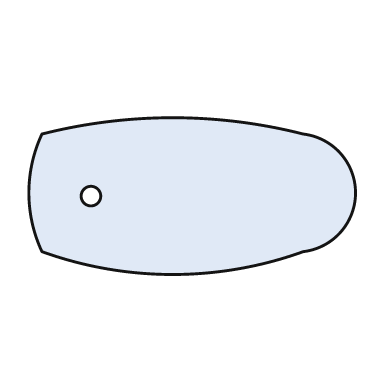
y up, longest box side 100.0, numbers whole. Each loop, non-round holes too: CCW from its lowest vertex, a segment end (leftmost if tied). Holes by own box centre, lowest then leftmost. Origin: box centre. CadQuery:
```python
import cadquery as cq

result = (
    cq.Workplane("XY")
    .moveTo(-46.0, -17.0)
    .threePointArc((-6.0, -24.0), (34.0, -17.0))
    .threePointArc((50.0, 1.0), (34.0, 19.0))
    .threePointArc((-6.0, 24.0), (-46.0, 19.0))
    .threePointArc((-50.0, 1.0), (-46.0, -17.0))
    .close()
    .moveTo(-31.0, 0.0)
    .circle(3.0)
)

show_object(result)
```